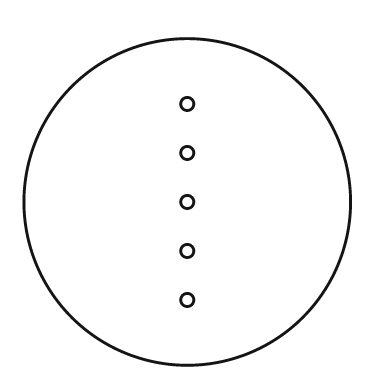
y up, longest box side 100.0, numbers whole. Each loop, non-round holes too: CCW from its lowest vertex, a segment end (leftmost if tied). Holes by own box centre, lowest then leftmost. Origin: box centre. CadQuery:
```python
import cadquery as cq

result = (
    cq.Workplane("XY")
    .moveTo(0.0, 0.0)
    .circle(50.0)
    .moveTo(0.0, -30.0)
    .circle(2.0)
    .moveTo(0.0, -15.0)
    .circle(2.0)
    .moveTo(0.0, 0.0)
    .circle(2.0)
    .moveTo(0.0, 15.0)
    .circle(2.0)
    .moveTo(0.0, 30.0)
    .circle(2.0)
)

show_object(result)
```